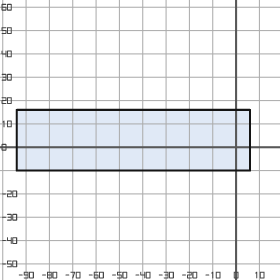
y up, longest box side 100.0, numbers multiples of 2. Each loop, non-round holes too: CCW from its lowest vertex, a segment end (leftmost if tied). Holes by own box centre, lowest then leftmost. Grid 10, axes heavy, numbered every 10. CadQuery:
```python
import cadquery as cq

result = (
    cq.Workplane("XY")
    .moveTo(-94.0, -10.0)
    .lineTo(6.0, -10.0)
    .lineTo(6.0, 16.0)
    .lineTo(-94.0, 16.0)
    .close()
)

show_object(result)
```